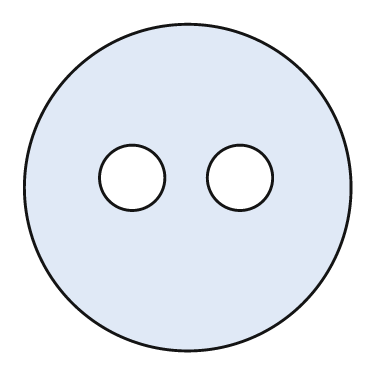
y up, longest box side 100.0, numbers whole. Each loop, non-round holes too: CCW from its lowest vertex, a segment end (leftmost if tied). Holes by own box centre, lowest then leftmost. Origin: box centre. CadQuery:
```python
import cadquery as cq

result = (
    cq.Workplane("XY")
    .moveTo(0.0, 0.0)
    .circle(50.0)
    .moveTo(-17.0, 3.0)
    .circle(10.0)
    .moveTo(16.0, 3.0)
    .circle(10.0)
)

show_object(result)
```